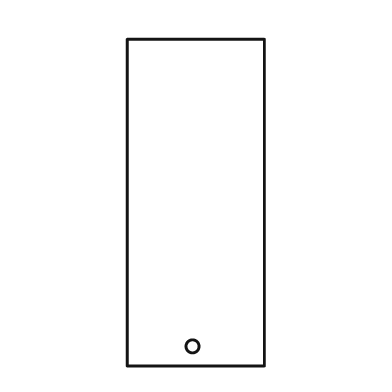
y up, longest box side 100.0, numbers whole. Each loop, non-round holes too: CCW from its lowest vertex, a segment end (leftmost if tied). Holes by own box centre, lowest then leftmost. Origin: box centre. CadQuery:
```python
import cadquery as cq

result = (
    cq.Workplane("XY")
    .moveTo(-21.0, -50.0)
    .lineTo(21.0, -50.0)
    .lineTo(21.0, 50.0)
    .lineTo(-21.0, 50.0)
    .close()
    .moveTo(-1.0, -44.0)
    .circle(2.0)
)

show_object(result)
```